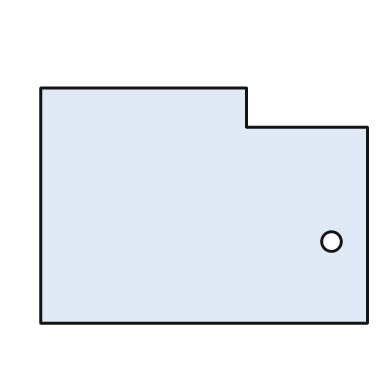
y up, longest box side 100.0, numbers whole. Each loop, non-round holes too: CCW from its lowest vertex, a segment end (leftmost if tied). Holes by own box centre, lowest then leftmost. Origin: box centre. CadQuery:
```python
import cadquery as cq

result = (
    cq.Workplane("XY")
    .moveTo(-50.0, -36.0)
    .lineTo(50.0, -36.0)
    .lineTo(50.0, 24.0)
    .lineTo(13.0, 24.0)
    .lineTo(13.0, 36.0)
    .lineTo(-50.0, 36.0)
    .close()
    .moveTo(39.0, -11.0)
    .circle(3.0)
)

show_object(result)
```